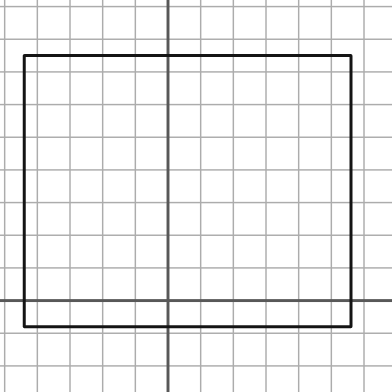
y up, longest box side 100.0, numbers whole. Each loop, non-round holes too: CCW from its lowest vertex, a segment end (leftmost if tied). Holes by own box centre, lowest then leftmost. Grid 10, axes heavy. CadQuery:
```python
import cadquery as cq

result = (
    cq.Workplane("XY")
    .moveTo(-44.0, -8.0)
    .lineTo(56.0, -8.0)
    .lineTo(56.0, 75.0)
    .lineTo(-44.0, 75.0)
    .close()
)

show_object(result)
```